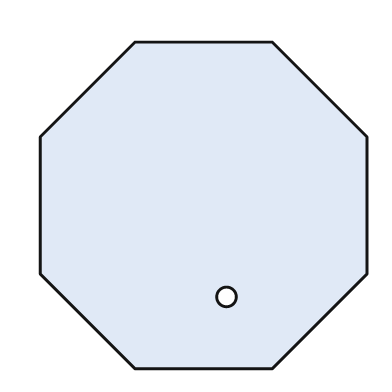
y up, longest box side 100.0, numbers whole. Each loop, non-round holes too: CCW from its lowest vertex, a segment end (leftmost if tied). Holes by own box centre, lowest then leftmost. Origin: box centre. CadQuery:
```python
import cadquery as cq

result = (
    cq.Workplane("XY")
    .moveTo(-21.0, -50.0)
    .lineTo(21.0, -50.0)
    .lineTo(50.0, -21.0)
    .lineTo(50.0, 21.0)
    .lineTo(21.0, 50.0)
    .lineTo(-21.0, 50.0)
    .lineTo(-50.0, 21.0)
    .lineTo(-50.0, -21.0)
    .close()
    .moveTo(7.0, -28.0)
    .circle(3.0)
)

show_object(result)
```